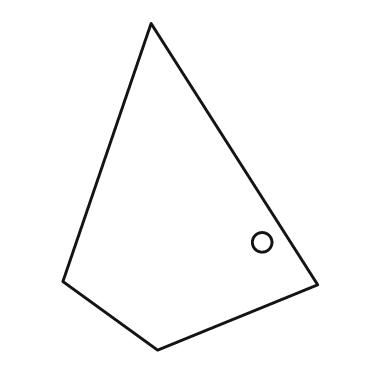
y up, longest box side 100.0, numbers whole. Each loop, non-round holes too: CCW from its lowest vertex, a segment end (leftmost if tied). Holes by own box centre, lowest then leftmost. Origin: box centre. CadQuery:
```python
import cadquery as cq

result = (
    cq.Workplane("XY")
    .moveTo(-10.0, -50.0)
    .lineTo(39.0, -30.0)
    .lineTo(-12.0, 50.0)
    .lineTo(-39.0, -29.0)
    .close()
    .moveTo(22.0, -17.0)
    .circle(3.0)
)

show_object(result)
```